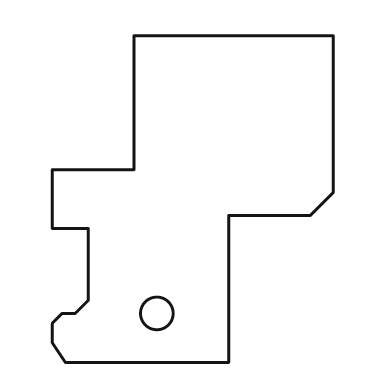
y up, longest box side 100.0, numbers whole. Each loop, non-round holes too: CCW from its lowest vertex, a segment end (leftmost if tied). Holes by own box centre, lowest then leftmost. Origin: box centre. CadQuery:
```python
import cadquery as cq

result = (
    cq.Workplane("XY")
    .moveTo(-39.0, -50.0)
    .lineTo(11.0, -50.0)
    .lineTo(11.0, -5.0)
    .lineTo(36.0, -5.0)
    .lineTo(43.0, 2.0)
    .lineTo(43.0, 50.0)
    .lineTo(-18.0, 50.0)
    .lineTo(-18.0, 9.0)
    .lineTo(-43.0, 9.0)
    .lineTo(-43.0, -9.0)
    .lineTo(-32.0, -9.0)
    .lineTo(-32.0, -31.0)
    .lineTo(-36.0, -35.0)
    .lineTo(-40.0, -35.0)
    .lineTo(-43.0, -38.0)
    .lineTo(-43.0, -44.0)
    .close()
    .moveTo(-11.0, -35.0)
    .circle(5.0)
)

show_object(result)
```